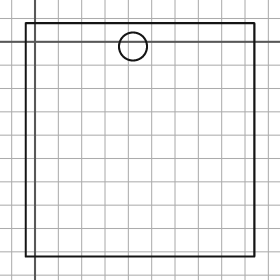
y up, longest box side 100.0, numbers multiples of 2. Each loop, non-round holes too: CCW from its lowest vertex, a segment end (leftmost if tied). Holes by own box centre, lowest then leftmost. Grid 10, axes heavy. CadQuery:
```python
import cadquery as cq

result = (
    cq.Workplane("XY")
    .moveTo(-4.0, -92.0)
    .lineTo(94.0, -92.0)
    .lineTo(94.0, 8.0)
    .lineTo(-4.0, 8.0)
    .close()
    .moveTo(42.0, -2.0)
    .circle(6.0)
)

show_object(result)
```